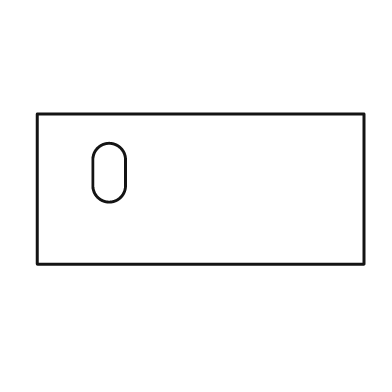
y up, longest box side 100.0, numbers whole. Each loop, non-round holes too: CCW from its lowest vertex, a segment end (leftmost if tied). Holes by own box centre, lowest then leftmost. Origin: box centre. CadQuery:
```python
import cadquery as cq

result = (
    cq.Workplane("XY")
    .moveTo(-50.0, -23.0)
    .lineTo(50.0, -23.0)
    .lineTo(50.0, 23.0)
    .lineTo(-50.0, 23.0)
    .close()
    .moveTo(-33.0, 1.0)
    .threePointArc((-28.0, -4.0), (-23.0, 1.0))
    .lineTo(-23.0, 9.0)
    .threePointArc((-28.0, 14.0), (-33.0, 9.0))
    .close()
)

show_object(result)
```